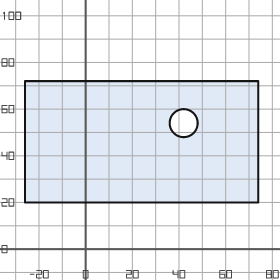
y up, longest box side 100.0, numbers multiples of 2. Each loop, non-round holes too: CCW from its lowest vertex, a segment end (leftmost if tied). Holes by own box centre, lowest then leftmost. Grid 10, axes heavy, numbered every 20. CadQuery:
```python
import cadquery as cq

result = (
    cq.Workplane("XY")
    .moveTo(-26.0, 20.0)
    .lineTo(74.0, 20.0)
    .lineTo(74.0, 72.0)
    .lineTo(-26.0, 72.0)
    .close()
    .moveTo(42.0, 54.0)
    .circle(6.0)
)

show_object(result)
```